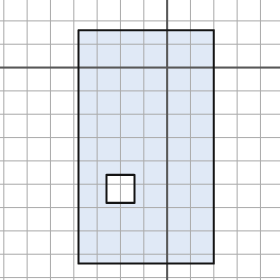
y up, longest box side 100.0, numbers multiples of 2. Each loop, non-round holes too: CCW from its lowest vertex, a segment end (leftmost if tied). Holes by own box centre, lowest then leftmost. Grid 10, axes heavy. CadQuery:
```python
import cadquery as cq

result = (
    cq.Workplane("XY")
    .moveTo(-38.0, -84.0)
    .lineTo(20.0, -84.0)
    .lineTo(20.0, 16.0)
    .lineTo(-38.0, 16.0)
    .close()
    .moveTo(-26.0, -58.0)
    .lineTo(-14.0, -58.0)
    .lineTo(-14.0, -46.0)
    .lineTo(-26.0, -46.0)
    .close()
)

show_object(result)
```